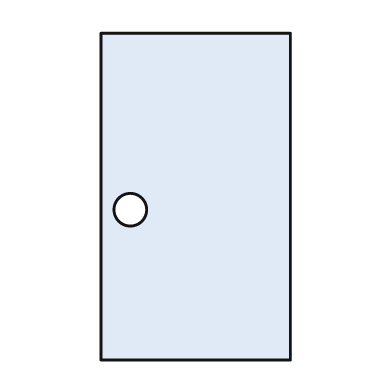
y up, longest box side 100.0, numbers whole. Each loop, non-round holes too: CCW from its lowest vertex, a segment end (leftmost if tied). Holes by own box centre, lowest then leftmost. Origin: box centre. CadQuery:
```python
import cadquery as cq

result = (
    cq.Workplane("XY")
    .moveTo(-29.0, -50.0)
    .lineTo(29.0, -50.0)
    .lineTo(29.0, 50.0)
    .lineTo(-29.0, 50.0)
    .close()
    .moveTo(-20.0, -4.0)
    .circle(5.0)
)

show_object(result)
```